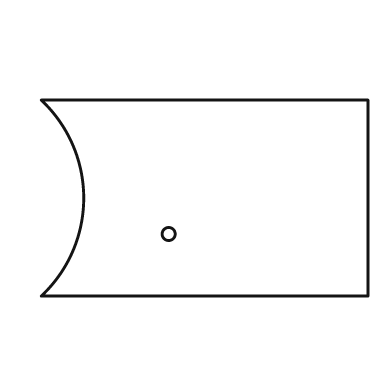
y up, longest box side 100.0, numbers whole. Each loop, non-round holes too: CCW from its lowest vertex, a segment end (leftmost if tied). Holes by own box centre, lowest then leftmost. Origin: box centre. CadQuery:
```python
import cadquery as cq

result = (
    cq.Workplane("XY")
    .moveTo(-50.0, -30.0)
    .lineTo(50.0, -30.0)
    .lineTo(50.0, 30.0)
    .lineTo(-50.0, 30.0)
    .threePointArc((-37.0, 0.0), (-50.0, -30.0))
    .close()
    .moveTo(-11.0, -11.0)
    .circle(2.0)
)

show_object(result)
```